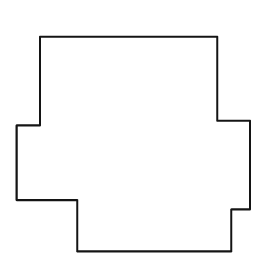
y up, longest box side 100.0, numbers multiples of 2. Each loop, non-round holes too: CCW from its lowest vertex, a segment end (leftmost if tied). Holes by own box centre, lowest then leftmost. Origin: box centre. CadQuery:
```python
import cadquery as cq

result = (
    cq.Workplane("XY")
    .moveTo(-24.0, -46.0)
    .lineTo(42.0, -46.0)
    .lineTo(42.0, -28.0)
    .lineTo(50.0, -28.0)
    .lineTo(50.0, 10.0)
    .lineTo(36.0, 10.0)
    .lineTo(36.0, 46.0)
    .lineTo(-40.0, 46.0)
    .lineTo(-40.0, 8.0)
    .lineTo(-50.0, 8.0)
    .lineTo(-50.0, -24.0)
    .lineTo(-24.0, -24.0)
    .close()
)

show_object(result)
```